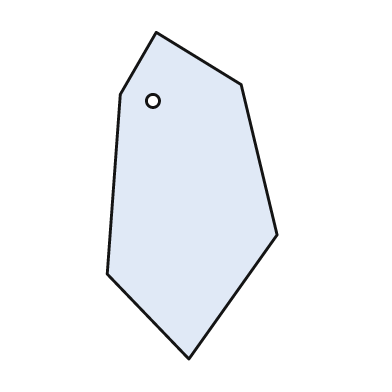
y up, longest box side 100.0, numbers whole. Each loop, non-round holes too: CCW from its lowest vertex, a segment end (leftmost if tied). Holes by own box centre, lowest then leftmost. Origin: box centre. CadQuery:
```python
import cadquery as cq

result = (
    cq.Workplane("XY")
    .moveTo(-1.0, -50.0)
    .lineTo(26.0, -12.0)
    .lineTo(15.0, 34.0)
    .lineTo(-11.0, 50.0)
    .lineTo(-22.0, 31.0)
    .lineTo(-26.0, -24.0)
    .close()
    .moveTo(-12.0, 29.0)
    .circle(2.0)
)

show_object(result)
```